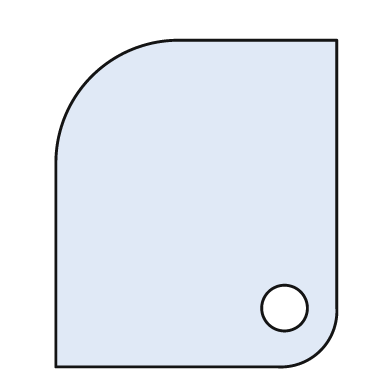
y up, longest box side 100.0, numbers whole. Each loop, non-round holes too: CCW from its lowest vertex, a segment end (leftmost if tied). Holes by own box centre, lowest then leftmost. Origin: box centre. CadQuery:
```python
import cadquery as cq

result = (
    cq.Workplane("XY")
    .moveTo(-43.0, -50.0)
    .lineTo(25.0, -50.0)
    .threePointArc((38.0, -45.0), (43.0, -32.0))
    .lineTo(43.0, 50.0)
    .lineTo(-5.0, 50.0)
    .threePointArc((-32.0, 39.0), (-43.0, 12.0))
    .close()
    .moveTo(27.0, -32.0)
    .circle(7.0)
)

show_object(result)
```